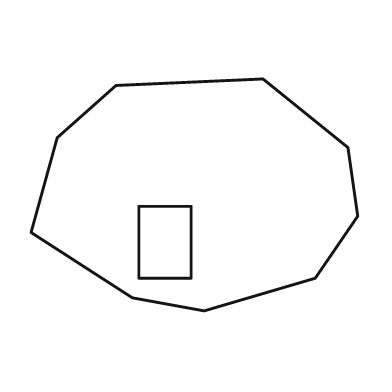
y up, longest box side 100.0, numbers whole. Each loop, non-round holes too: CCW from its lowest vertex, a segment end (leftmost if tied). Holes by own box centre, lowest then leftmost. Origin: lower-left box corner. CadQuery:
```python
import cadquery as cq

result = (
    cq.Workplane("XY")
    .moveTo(53.0, 0.0)
    .lineTo(87.0, 10.0)
    .lineTo(100.0, 29.0)
    .lineTo(97.0, 50.0)
    .lineTo(71.0, 71.0)
    .lineTo(26.0, 69.0)
    .lineTo(8.0, 53.0)
    .lineTo(0.0, 24.0)
    .lineTo(31.0, 4.0)
    .close()
    .moveTo(33.0, 10.0)
    .lineTo(49.0, 10.0)
    .lineTo(49.0, 32.0)
    .lineTo(33.0, 32.0)
    .close()
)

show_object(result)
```